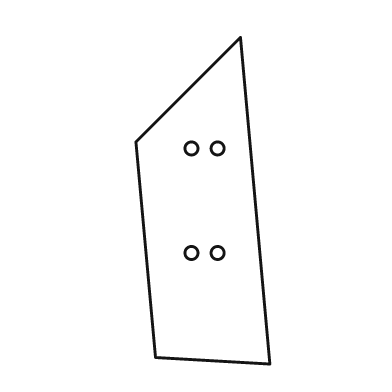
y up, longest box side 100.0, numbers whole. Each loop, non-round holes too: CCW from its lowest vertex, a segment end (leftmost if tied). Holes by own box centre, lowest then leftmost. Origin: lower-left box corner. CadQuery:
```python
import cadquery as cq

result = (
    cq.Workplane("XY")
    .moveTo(41.0, 0.0)
    .lineTo(32.0, 100.0)
    .lineTo(0.0, 68.0)
    .lineTo(6.0, 2.0)
    .close()
    .moveTo(17.0, 34.0)
    .circle(2.0)
    .moveTo(25.0, 34.0)
    .circle(2.0)
    .moveTo(17.0, 66.0)
    .circle(2.0)
    .moveTo(25.0, 66.0)
    .circle(2.0)
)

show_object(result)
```